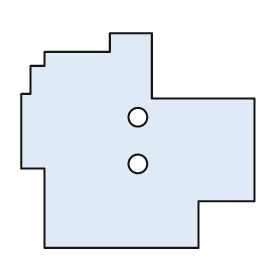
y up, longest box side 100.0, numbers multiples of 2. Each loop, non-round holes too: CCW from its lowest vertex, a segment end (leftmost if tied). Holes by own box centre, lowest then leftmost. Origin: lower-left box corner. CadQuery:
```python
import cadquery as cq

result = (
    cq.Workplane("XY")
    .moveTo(10.0, 0.0)
    .lineTo(76.0, 0.0)
    .lineTo(76.0, 20.0)
    .lineTo(100.0, 20.0)
    .lineTo(100.0, 64.0)
    .lineTo(56.0, 64.0)
    .lineTo(56.0, 92.0)
    .lineTo(38.0, 92.0)
    .lineTo(38.0, 84.0)
    .lineTo(10.0, 84.0)
    .lineTo(10.0, 78.0)
    .lineTo(4.0, 78.0)
    .lineTo(4.0, 66.0)
    .lineTo(0.0, 66.0)
    .lineTo(0.0, 34.0)
    .lineTo(10.0, 34.0)
    .close()
    .moveTo(50.0, 36.0)
    .circle(4.0)
    .moveTo(50.0, 56.0)
    .circle(4.0)
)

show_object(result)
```